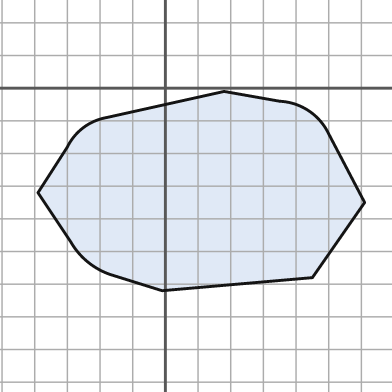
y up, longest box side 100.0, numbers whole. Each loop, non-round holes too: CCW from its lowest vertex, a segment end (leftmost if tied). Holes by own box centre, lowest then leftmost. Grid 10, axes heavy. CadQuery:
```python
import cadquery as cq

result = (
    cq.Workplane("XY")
    .moveTo(-1.0, -62.0)
    .lineTo(45.0, -58.0)
    .lineTo(61.0, -35.0)
    .lineTo(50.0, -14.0)
    .threePointArc((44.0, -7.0), (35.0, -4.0))
    .lineTo(18.0, -1.0)
    .lineTo(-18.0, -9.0)
    .threePointArc((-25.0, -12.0), (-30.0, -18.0))
    .lineTo(-39.0, -32.0)
    .lineTo(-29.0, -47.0)
    .threePointArc((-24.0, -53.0), (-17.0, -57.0))
    .close()
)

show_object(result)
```